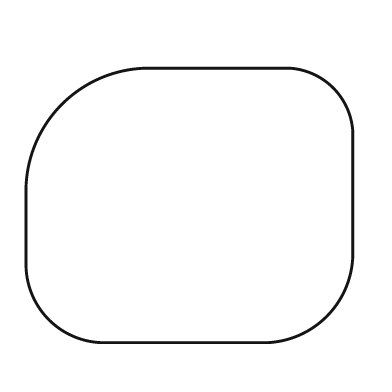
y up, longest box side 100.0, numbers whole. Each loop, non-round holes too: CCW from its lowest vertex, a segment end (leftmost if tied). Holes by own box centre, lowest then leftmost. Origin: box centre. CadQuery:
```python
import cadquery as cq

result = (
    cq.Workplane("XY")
    .moveTo(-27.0, -42.0)
    .lineTo(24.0, -42.0)
    .threePointArc((42.0, -34.0), (50.0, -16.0))
    .lineTo(50.0, 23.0)
    .threePointArc((44.0, 36.0), (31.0, 42.0))
    .lineTo(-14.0, 42.0)
    .threePointArc((-39.0, 31.0), (-50.0, 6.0))
    .lineTo(-50.0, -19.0)
    .threePointArc((-43.0, -35.0), (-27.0, -42.0))
    .close()
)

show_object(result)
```